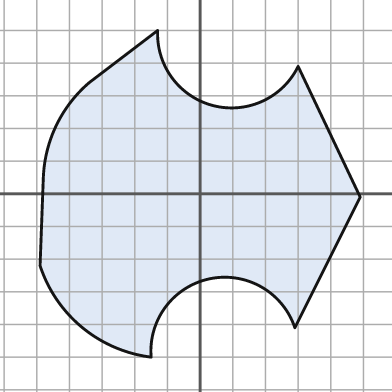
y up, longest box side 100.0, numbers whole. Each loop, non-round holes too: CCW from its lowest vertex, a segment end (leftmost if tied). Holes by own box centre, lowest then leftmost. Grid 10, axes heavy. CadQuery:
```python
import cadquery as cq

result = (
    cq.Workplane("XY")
    .moveTo(-15.0, -50.0)
    .threePointArc((3.0, -26.0), (29.0, -41.0))
    .lineTo(49.0, -1.0)
    .lineTo(30.0, 39.0)
    .threePointArc((4.0, 27.0), (-13.0, 50.0))
    .lineTo(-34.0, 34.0)
    .threePointArc((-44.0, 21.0), (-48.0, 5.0))
    .lineTo(-49.0, -22.0)
    .threePointArc((-36.0, -41.0), (-15.0, -50.0))
    .close()
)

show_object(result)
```